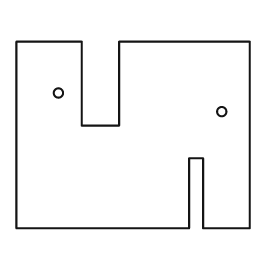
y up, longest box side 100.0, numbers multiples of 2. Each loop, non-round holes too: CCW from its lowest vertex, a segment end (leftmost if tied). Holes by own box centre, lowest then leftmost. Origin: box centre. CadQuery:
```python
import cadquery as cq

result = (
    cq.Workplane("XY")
    .moveTo(-50.0, -40.0)
    .lineTo(24.0, -40.0)
    .lineTo(24.0, -10.0)
    .lineTo(30.0, -10.0)
    .lineTo(30.0, -40.0)
    .lineTo(50.0, -40.0)
    .lineTo(50.0, 40.0)
    .lineTo(-6.0, 40.0)
    .lineTo(-6.0, 4.0)
    .lineTo(-22.0, 4.0)
    .lineTo(-22.0, 40.0)
    .lineTo(-50.0, 40.0)
    .close()
    .moveTo(38.0, 10.0)
    .circle(2.0)
    .moveTo(-32.0, 18.0)
    .circle(2.0)
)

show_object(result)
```